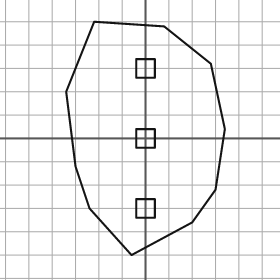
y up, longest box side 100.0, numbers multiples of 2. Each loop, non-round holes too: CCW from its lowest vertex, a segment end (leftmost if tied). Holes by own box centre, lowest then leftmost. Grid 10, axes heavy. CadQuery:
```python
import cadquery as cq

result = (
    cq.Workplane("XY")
    .moveTo(-6.0, -50.0)
    .lineTo(20.0, -36.0)
    .lineTo(30.0, -22.0)
    .lineTo(34.0, 4.0)
    .lineTo(28.0, 32.0)
    .lineTo(8.0, 48.0)
    .lineTo(-22.0, 50.0)
    .lineTo(-34.0, 20.0)
    .lineTo(-30.0, -12.0)
    .lineTo(-24.0, -30.0)
    .close()
    .moveTo(-4.0, -34.0)
    .lineTo(4.0, -34.0)
    .lineTo(4.0, -26.0)
    .lineTo(-4.0, -26.0)
    .close()
    .moveTo(-4.0, -4.0)
    .lineTo(4.0, -4.0)
    .lineTo(4.0, 4.0)
    .lineTo(-4.0, 4.0)
    .close()
    .moveTo(-4.0, 26.0)
    .lineTo(4.0, 26.0)
    .lineTo(4.0, 34.0)
    .lineTo(-4.0, 34.0)
    .close()
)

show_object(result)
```